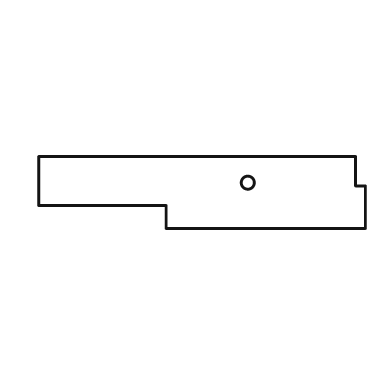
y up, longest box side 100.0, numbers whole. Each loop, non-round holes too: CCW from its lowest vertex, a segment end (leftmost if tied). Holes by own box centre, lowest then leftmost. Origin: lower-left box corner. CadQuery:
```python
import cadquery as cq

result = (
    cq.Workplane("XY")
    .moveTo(39.0, 0.0)
    .lineTo(100.0, 0.0)
    .lineTo(100.0, 13.0)
    .lineTo(97.0, 13.0)
    .lineTo(97.0, 22.0)
    .lineTo(0.0, 22.0)
    .lineTo(0.0, 7.0)
    .lineTo(39.0, 7.0)
    .close()
    .moveTo(64.0, 14.0)
    .circle(2.0)
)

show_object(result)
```